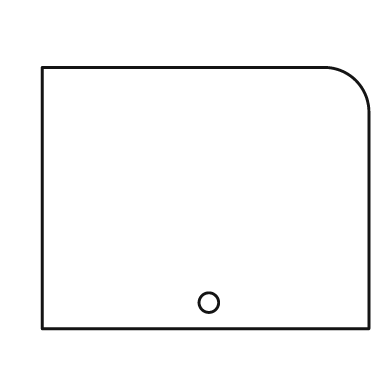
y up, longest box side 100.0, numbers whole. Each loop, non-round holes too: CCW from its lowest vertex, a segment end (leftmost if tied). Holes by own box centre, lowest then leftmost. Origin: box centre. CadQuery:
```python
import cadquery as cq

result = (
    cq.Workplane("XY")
    .moveTo(-50.0, -40.0)
    .lineTo(50.0, -40.0)
    .lineTo(50.0, 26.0)
    .threePointArc((46.0, 36.0), (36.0, 40.0))
    .lineTo(-50.0, 40.0)
    .close()
    .moveTo(1.0, -32.0)
    .circle(3.0)
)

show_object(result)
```